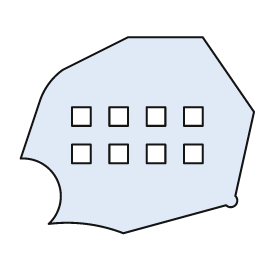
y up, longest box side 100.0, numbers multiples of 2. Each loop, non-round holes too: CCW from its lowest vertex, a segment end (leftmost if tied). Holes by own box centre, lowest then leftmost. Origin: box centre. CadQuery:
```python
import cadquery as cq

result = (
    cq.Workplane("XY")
    .moveTo(-6.0, -42.0)
    .lineTo(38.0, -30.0)
    .threePointArc((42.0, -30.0), (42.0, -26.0))
    .lineTo(50.0, 10.0)
    .lineTo(28.0, 42.0)
    .lineTo(-4.0, 42.0)
    .lineTo(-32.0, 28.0)
    .threePointArc((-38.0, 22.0), (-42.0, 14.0))
    .lineTo(-50.0, -10.0)
    .threePointArc((-34.0, -20.0), (-38.0, -38.0))
    .threePointArc((-22.0, -38.0), (-6.0, -42.0))
    .close()
    .moveTo(-28.0, -12.0)
    .lineTo(-20.0, -12.0)
    .lineTo(-20.0, -4.0)
    .lineTo(-28.0, -4.0)
    .close()
    .moveTo(-12.0, -12.0)
    .lineTo(-4.0, -12.0)
    .lineTo(-4.0, -4.0)
    .lineTo(-12.0, -4.0)
    .close()
    .moveTo(4.0, -12.0)
    .lineTo(12.0, -12.0)
    .lineTo(12.0, -4.0)
    .lineTo(4.0, -4.0)
    .close()
    .moveTo(20.0, -12.0)
    .lineTo(28.0, -12.0)
    .lineTo(28.0, -4.0)
    .lineTo(20.0, -4.0)
    .close()
    .moveTo(-28.0, 4.0)
    .lineTo(-20.0, 4.0)
    .lineTo(-20.0, 12.0)
    .lineTo(-28.0, 12.0)
    .close()
    .moveTo(-12.0, 4.0)
    .lineTo(-4.0, 4.0)
    .lineTo(-4.0, 12.0)
    .lineTo(-12.0, 12.0)
    .close()
    .moveTo(4.0, 4.0)
    .lineTo(12.0, 4.0)
    .lineTo(12.0, 12.0)
    .lineTo(4.0, 12.0)
    .close()
    .moveTo(20.0, 4.0)
    .lineTo(28.0, 4.0)
    .lineTo(28.0, 12.0)
    .lineTo(20.0, 12.0)
    .close()
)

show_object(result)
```